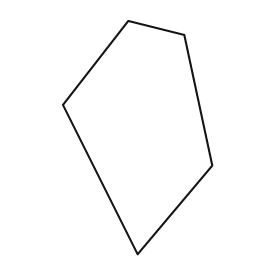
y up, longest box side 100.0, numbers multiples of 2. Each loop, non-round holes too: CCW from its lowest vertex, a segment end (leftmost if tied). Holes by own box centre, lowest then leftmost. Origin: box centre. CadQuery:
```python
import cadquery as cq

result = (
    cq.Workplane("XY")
    .moveTo(0.0, -50.0)
    .lineTo(32.0, -12.0)
    .lineTo(20.0, 44.0)
    .lineTo(-4.0, 50.0)
    .lineTo(-32.0, 14.0)
    .close()
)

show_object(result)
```